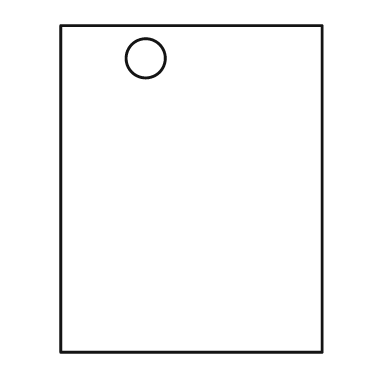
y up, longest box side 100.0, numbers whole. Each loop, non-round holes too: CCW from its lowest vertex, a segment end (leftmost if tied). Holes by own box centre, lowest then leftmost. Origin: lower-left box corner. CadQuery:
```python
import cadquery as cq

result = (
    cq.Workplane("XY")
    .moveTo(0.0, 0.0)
    .lineTo(80.0, 0.0)
    .lineTo(80.0, 100.0)
    .lineTo(0.0, 100.0)
    .close()
    .moveTo(26.0, 90.0)
    .circle(6.0)
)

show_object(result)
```